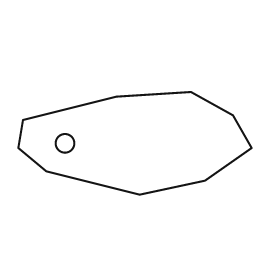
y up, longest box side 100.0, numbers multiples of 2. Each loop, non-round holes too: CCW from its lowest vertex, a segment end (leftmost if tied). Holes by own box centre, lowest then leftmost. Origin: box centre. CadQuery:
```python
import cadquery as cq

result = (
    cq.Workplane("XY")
    .moveTo(2.0, -22.0)
    .lineTo(30.0, -16.0)
    .lineTo(50.0, -2.0)
    .lineTo(42.0, 12.0)
    .lineTo(24.0, 22.0)
    .lineTo(-8.0, 20.0)
    .lineTo(-48.0, 10.0)
    .lineTo(-50.0, -2.0)
    .lineTo(-38.0, -12.0)
    .close()
    .moveTo(-30.0, 0.0)
    .circle(4.0)
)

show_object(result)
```